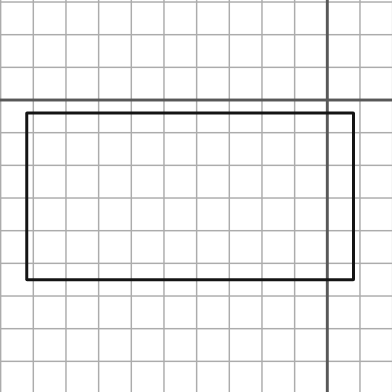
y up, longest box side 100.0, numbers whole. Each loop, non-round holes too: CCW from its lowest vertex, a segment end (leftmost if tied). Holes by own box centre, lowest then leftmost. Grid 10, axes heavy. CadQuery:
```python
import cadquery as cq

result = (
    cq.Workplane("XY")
    .moveTo(-92.0, -55.0)
    .lineTo(8.0, -55.0)
    .lineTo(8.0, -4.0)
    .lineTo(-92.0, -4.0)
    .close()
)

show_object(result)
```